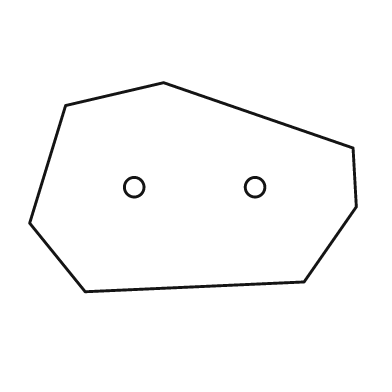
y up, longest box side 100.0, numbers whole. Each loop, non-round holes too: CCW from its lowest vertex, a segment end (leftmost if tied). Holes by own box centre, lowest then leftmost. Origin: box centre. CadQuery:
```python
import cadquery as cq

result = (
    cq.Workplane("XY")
    .moveTo(-33.0, -32.0)
    .lineTo(34.0, -29.0)
    .lineTo(50.0, -6.0)
    .lineTo(49.0, 12.0)
    .lineTo(-9.0, 32.0)
    .lineTo(-39.0, 25.0)
    .lineTo(-50.0, -11.0)
    .close()
    .moveTo(-18.0, 0.0)
    .circle(3.0)
    .moveTo(19.0, 0.0)
    .circle(3.0)
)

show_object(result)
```